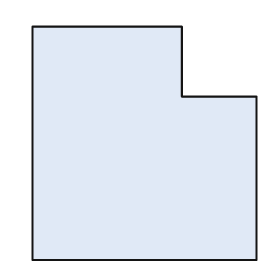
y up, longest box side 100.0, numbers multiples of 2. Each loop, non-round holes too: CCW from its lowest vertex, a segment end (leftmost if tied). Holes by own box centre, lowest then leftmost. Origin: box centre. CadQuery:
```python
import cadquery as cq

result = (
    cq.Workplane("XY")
    .moveTo(-48.0, -50.0)
    .lineTo(48.0, -50.0)
    .lineTo(48.0, 20.0)
    .lineTo(16.0, 20.0)
    .lineTo(16.0, 50.0)
    .lineTo(-48.0, 50.0)
    .close()
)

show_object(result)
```